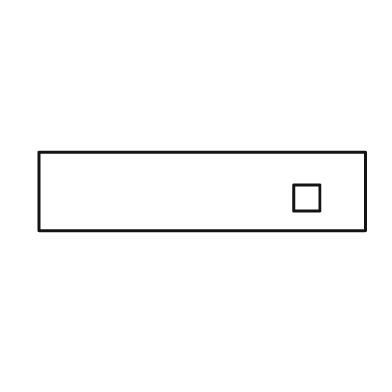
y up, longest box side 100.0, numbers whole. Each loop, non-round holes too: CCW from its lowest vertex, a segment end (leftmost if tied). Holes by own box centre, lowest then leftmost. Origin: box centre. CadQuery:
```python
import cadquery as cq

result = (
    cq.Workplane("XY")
    .moveTo(-50.0, -12.0)
    .lineTo(50.0, -12.0)
    .lineTo(50.0, 12.0)
    .lineTo(-50.0, 12.0)
    .close()
    .moveTo(28.0, -6.0)
    .lineTo(36.0, -6.0)
    .lineTo(36.0, 2.0)
    .lineTo(28.0, 2.0)
    .close()
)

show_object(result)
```